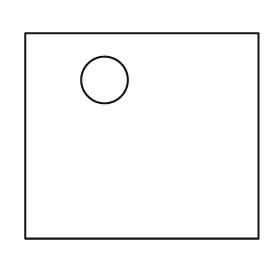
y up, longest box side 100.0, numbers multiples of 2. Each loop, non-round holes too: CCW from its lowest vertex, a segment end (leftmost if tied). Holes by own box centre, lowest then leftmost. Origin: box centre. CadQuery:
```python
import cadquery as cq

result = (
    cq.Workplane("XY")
    .moveTo(-50.0, -44.0)
    .lineTo(50.0, -44.0)
    .lineTo(50.0, 44.0)
    .lineTo(-50.0, 44.0)
    .close()
    .moveTo(-16.0, 24.0)
    .circle(10.0)
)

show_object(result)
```